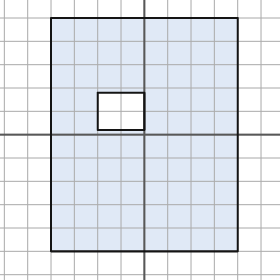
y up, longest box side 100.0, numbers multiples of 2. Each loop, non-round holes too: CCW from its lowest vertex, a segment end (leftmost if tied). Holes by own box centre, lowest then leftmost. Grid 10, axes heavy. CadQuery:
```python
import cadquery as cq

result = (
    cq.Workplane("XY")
    .moveTo(-40.0, -50.0)
    .lineTo(40.0, -50.0)
    .lineTo(40.0, 50.0)
    .lineTo(-40.0, 50.0)
    .close()
    .moveTo(-20.0, 2.0)
    .lineTo(0.0, 2.0)
    .lineTo(0.0, 18.0)
    .lineTo(-20.0, 18.0)
    .close()
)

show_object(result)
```